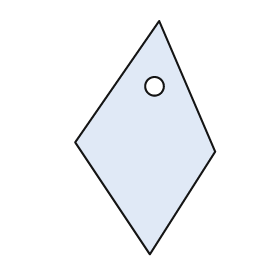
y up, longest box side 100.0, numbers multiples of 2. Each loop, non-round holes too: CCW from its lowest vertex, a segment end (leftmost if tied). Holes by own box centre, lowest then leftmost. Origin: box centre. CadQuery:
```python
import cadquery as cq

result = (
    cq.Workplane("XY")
    .moveTo(2.0, -50.0)
    .lineTo(30.0, -6.0)
    .lineTo(6.0, 50.0)
    .lineTo(-30.0, -2.0)
    .close()
    .moveTo(4.0, 22.0)
    .circle(4.0)
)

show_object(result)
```